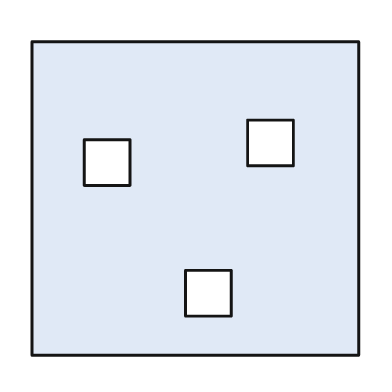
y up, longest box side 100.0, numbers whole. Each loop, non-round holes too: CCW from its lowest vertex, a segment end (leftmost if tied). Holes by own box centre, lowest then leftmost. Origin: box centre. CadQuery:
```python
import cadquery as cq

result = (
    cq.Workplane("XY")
    .moveTo(-50.0, -48.0)
    .lineTo(50.0, -48.0)
    .lineTo(50.0, 48.0)
    .lineTo(-50.0, 48.0)
    .close()
    .moveTo(-3.0, -36.0)
    .lineTo(11.0, -36.0)
    .lineTo(11.0, -22.0)
    .lineTo(-3.0, -22.0)
    .close()
    .moveTo(-34.0, 4.0)
    .lineTo(-20.0, 4.0)
    .lineTo(-20.0, 18.0)
    .lineTo(-34.0, 18.0)
    .close()
    .moveTo(16.0, 10.0)
    .lineTo(30.0, 10.0)
    .lineTo(30.0, 24.0)
    .lineTo(16.0, 24.0)
    .close()
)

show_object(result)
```